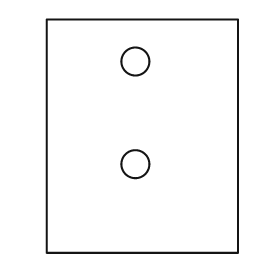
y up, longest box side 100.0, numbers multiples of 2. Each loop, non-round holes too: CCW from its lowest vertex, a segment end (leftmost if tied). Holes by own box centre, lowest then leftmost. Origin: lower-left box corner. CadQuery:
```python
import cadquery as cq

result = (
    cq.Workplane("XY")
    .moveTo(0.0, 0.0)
    .lineTo(82.0, 0.0)
    .lineTo(82.0, 100.0)
    .lineTo(0.0, 100.0)
    .close()
    .moveTo(38.0, 38.0)
    .circle(6.0)
    .moveTo(38.0, 82.0)
    .circle(6.0)
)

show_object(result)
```